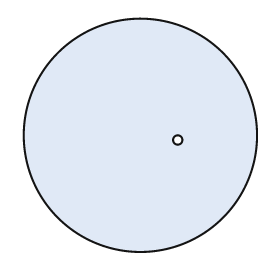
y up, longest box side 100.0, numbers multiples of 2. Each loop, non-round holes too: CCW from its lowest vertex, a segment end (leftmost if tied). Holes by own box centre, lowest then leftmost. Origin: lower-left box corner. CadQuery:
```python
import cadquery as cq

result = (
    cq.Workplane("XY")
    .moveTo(50.0, 50.0)
    .circle(50.0)
    .moveTo(66.0, 48.0)
    .circle(2.0)
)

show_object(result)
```